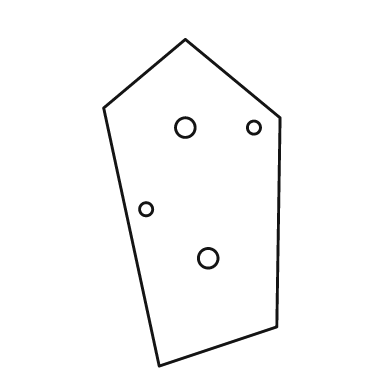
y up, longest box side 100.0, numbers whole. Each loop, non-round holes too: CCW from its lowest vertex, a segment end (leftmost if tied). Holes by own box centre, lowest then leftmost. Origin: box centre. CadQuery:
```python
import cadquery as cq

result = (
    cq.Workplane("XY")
    .moveTo(-10.0, -50.0)
    .lineTo(26.0, -38.0)
    .lineTo(27.0, 26.0)
    .lineTo(-2.0, 50.0)
    .lineTo(-27.0, 29.0)
    .close()
    .moveTo(5.0, -17.0)
    .circle(3.0)
    .moveTo(-14.0, -2.0)
    .circle(2.0)
    .moveTo(-2.0, 23.0)
    .circle(3.0)
    .moveTo(19.0, 23.0)
    .circle(2.0)
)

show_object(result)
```